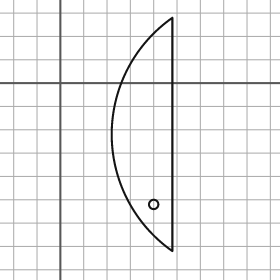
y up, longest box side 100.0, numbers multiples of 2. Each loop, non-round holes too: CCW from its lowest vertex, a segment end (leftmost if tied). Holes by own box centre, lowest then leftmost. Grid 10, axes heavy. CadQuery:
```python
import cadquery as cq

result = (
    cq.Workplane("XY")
    .moveTo(48.0, -72.0)
    .lineTo(48.0, 28.0)
    .threePointArc((22.0, -22.0), (48.0, -72.0))
    .close()
    .moveTo(40.0, -52.0)
    .circle(2.0)
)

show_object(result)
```